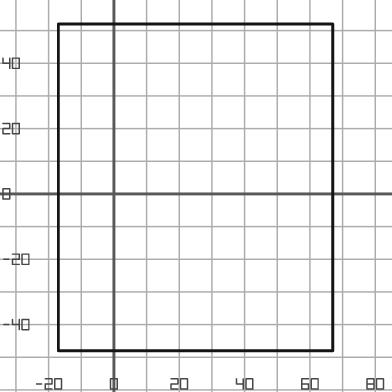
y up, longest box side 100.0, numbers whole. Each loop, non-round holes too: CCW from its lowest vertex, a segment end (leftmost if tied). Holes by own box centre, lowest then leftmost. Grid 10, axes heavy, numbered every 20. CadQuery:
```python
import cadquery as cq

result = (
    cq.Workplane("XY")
    .moveTo(-17.0, -48.0)
    .lineTo(67.0, -48.0)
    .lineTo(67.0, 52.0)
    .lineTo(-17.0, 52.0)
    .close()
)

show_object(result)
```